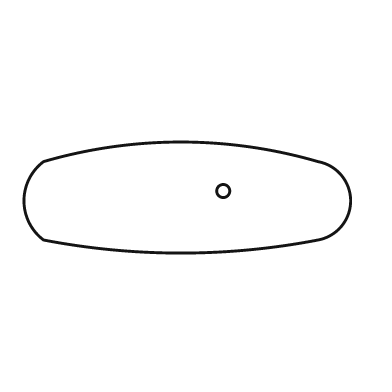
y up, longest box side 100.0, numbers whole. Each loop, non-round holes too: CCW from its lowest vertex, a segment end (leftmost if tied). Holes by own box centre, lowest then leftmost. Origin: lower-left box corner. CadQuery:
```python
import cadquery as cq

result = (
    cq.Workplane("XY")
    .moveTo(6.0, 4.0)
    .threePointArc((48.0, 0.0), (90.0, 4.0))
    .threePointArc((100.0, 16.0), (90.0, 28.0))
    .threePointArc((48.0, 34.0), (6.0, 28.0))
    .threePointArc((0.0, 16.0), (6.0, 4.0))
    .close()
    .moveTo(61.0, 19.0)
    .circle(2.0)
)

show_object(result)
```